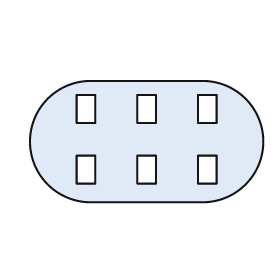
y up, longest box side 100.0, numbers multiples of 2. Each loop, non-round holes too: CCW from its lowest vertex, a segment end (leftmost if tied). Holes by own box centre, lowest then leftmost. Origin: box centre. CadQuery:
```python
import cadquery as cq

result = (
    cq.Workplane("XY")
    .moveTo(-24.0, -26.0)
    .lineTo(24.0, -26.0)
    .threePointArc((50.0, 0.0), (24.0, 26.0))
    .lineTo(-24.0, 26.0)
    .threePointArc((-50.0, 0.0), (-24.0, -26.0))
    .close()
    .moveTo(-30.0, -18.0)
    .lineTo(-22.0, -18.0)
    .lineTo(-22.0, -6.0)
    .lineTo(-30.0, -6.0)
    .close()
    .moveTo(-4.0, -18.0)
    .lineTo(4.0, -18.0)
    .lineTo(4.0, -6.0)
    .lineTo(-4.0, -6.0)
    .close()
    .moveTo(22.0, -18.0)
    .lineTo(30.0, -18.0)
    .lineTo(30.0, -6.0)
    .lineTo(22.0, -6.0)
    .close()
    .moveTo(-30.0, 8.0)
    .lineTo(-22.0, 8.0)
    .lineTo(-22.0, 20.0)
    .lineTo(-30.0, 20.0)
    .close()
    .moveTo(-4.0, 8.0)
    .lineTo(4.0, 8.0)
    .lineTo(4.0, 20.0)
    .lineTo(-4.0, 20.0)
    .close()
    .moveTo(22.0, 8.0)
    .lineTo(30.0, 8.0)
    .lineTo(30.0, 20.0)
    .lineTo(22.0, 20.0)
    .close()
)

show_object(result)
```